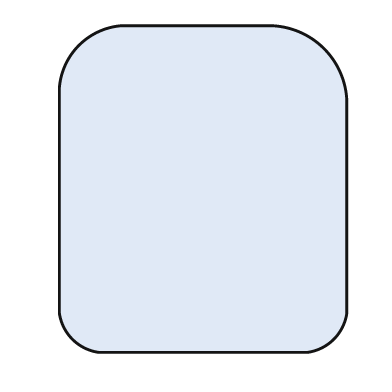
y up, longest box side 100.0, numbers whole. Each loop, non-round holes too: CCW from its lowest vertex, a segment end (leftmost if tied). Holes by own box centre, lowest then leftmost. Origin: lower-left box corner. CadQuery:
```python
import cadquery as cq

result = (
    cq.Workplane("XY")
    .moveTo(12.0, 0.0)
    .lineTo(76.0, 0.0)
    .threePointArc((84.0, 4.0), (88.0, 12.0))
    .lineTo(88.0, 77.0)
    .threePointArc((81.0, 93.0), (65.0, 100.0))
    .lineTo(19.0, 100.0)
    .threePointArc((6.0, 94.0), (0.0, 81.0))
    .lineTo(0.0, 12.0)
    .threePointArc((4.0, 4.0), (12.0, 0.0))
    .close()
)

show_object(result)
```